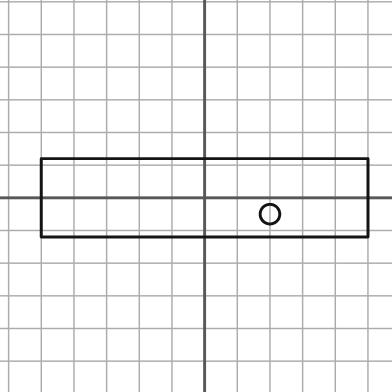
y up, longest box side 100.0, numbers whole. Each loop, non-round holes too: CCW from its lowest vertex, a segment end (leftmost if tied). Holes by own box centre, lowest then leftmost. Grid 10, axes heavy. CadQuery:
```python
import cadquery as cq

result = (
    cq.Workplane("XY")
    .moveTo(-50.0, -12.0)
    .lineTo(50.0, -12.0)
    .lineTo(50.0, 12.0)
    .lineTo(-50.0, 12.0)
    .close()
    .moveTo(20.0, -5.0)
    .circle(3.0)
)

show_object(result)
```